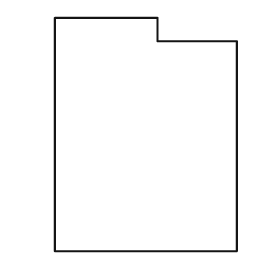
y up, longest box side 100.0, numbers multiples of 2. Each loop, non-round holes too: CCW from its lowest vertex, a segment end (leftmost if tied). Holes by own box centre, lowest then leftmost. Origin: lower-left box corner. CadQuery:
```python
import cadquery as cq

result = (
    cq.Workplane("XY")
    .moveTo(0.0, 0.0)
    .lineTo(78.0, 0.0)
    .lineTo(78.0, 90.0)
    .lineTo(44.0, 90.0)
    .lineTo(44.0, 100.0)
    .lineTo(0.0, 100.0)
    .close()
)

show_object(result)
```